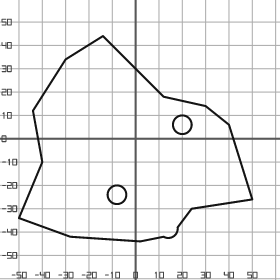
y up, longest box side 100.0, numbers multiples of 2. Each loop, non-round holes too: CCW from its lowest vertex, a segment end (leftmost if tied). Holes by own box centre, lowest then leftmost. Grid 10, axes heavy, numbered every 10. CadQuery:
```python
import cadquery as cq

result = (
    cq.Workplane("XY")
    .moveTo(2.0, -44.0)
    .lineTo(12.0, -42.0)
    .threePointArc((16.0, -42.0), (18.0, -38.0))
    .lineTo(24.0, -30.0)
    .lineTo(50.0, -26.0)
    .lineTo(40.0, 6.0)
    .lineTo(30.0, 14.0)
    .lineTo(12.0, 18.0)
    .lineTo(-14.0, 44.0)
    .lineTo(-30.0, 34.0)
    .lineTo(-44.0, 12.0)
    .lineTo(-40.0, -10.0)
    .lineTo(-50.0, -34.0)
    .lineTo(-28.0, -42.0)
    .close()
    .moveTo(-8.0, -24.0)
    .circle(4.0)
    .moveTo(20.0, 6.0)
    .circle(4.0)
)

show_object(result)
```